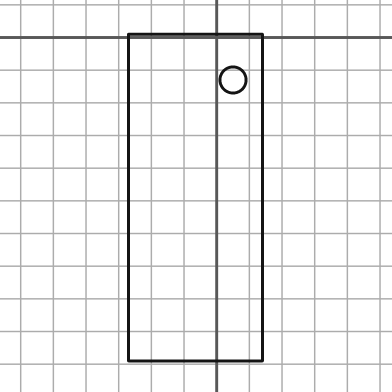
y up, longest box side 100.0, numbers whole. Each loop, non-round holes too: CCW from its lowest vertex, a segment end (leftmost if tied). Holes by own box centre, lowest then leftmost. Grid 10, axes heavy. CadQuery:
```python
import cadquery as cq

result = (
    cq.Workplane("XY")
    .moveTo(-27.0, -99.0)
    .lineTo(14.0, -99.0)
    .lineTo(14.0, 1.0)
    .lineTo(-27.0, 1.0)
    .close()
    .moveTo(5.0, -13.0)
    .circle(4.0)
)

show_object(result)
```